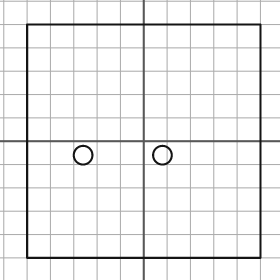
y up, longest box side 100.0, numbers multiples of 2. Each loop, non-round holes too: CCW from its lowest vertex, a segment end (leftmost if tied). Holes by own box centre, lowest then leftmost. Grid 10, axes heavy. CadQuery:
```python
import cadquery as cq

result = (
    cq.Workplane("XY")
    .moveTo(-50.0, -50.0)
    .lineTo(50.0, -50.0)
    .lineTo(50.0, 50.0)
    .lineTo(-50.0, 50.0)
    .close()
    .moveTo(-26.0, -6.0)
    .circle(4.0)
    .moveTo(8.0, -6.0)
    .circle(4.0)
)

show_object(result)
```